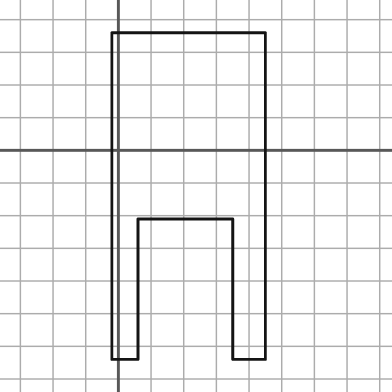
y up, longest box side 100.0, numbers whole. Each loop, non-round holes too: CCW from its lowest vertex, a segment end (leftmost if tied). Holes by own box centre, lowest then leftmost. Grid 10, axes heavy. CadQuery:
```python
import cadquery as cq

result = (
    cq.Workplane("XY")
    .moveTo(-2.0, -64.0)
    .lineTo(6.0, -64.0)
    .lineTo(6.0, -21.0)
    .lineTo(35.0, -21.0)
    .lineTo(35.0, -64.0)
    .lineTo(45.0, -64.0)
    .lineTo(45.0, 36.0)
    .lineTo(-2.0, 36.0)
    .close()
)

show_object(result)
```